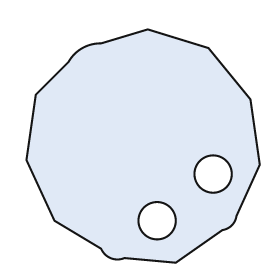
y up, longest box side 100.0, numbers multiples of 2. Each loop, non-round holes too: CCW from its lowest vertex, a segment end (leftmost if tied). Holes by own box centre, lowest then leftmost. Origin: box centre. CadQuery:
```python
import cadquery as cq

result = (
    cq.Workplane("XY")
    .moveTo(14.0, -50.0)
    .lineTo(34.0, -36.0)
    .threePointArc((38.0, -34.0), (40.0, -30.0))
    .lineTo(50.0, -8.0)
    .lineTo(46.0, 20.0)
    .lineTo(28.0, 42.0)
    .lineTo(2.0, 50.0)
    .lineTo(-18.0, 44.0)
    .threePointArc((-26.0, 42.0), (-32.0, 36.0))
    .lineTo(-46.0, 22.0)
    .lineTo(-50.0, -6.0)
    .lineTo(-38.0, -32.0)
    .lineTo(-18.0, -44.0)
    .threePointArc((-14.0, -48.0), (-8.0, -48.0))
    .close()
    .moveTo(6.0, -32.0)
    .circle(8.0)
    .moveTo(30.0, -12.0)
    .circle(8.0)
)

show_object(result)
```